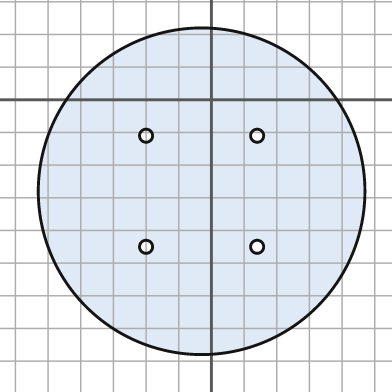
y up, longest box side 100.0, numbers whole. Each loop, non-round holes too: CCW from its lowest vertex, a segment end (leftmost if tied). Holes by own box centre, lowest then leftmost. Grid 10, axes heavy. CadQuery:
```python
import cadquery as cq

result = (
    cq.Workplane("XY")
    .moveTo(-3.0, -28.0)
    .circle(50.0)
    .moveTo(-20.0, -45.0)
    .circle(2.0)
    .moveTo(14.0, -45.0)
    .circle(2.0)
    .moveTo(-20.0, -11.0)
    .circle(2.0)
    .moveTo(14.0, -11.0)
    .circle(2.0)
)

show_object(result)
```